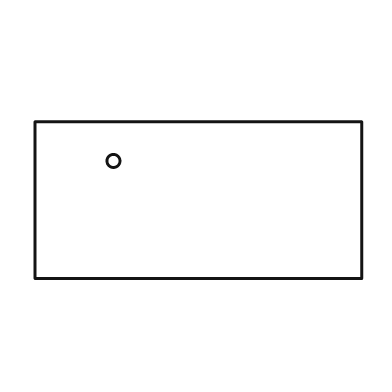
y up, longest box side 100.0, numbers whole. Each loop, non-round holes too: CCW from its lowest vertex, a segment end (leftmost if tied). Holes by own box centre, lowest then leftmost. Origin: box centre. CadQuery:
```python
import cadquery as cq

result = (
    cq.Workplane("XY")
    .moveTo(-50.0, -24.0)
    .lineTo(50.0, -24.0)
    .lineTo(50.0, 24.0)
    .lineTo(-50.0, 24.0)
    .close()
    .moveTo(-26.0, 12.0)
    .circle(2.0)
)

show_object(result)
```